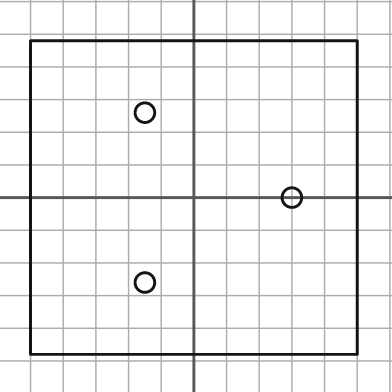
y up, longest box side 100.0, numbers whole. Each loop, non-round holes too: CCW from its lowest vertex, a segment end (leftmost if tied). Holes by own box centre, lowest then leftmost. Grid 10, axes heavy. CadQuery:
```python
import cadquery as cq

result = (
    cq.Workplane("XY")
    .moveTo(-50.0, -48.0)
    .lineTo(50.0, -48.0)
    .lineTo(50.0, 48.0)
    .lineTo(-50.0, 48.0)
    .close()
    .moveTo(-15.0, -26.0)
    .circle(3.0)
    .moveTo(30.0, 0.0)
    .circle(3.0)
    .moveTo(-15.0, 26.0)
    .circle(3.0)
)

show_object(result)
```